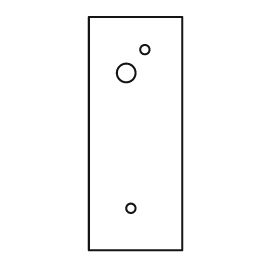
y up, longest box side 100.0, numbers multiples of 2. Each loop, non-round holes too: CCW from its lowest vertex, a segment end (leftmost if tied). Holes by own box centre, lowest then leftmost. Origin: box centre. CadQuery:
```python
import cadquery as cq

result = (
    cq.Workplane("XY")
    .moveTo(-20.0, -50.0)
    .lineTo(20.0, -50.0)
    .lineTo(20.0, 50.0)
    .lineTo(-20.0, 50.0)
    .close()
    .moveTo(-2.0, -32.0)
    .circle(2.0)
    .moveTo(-4.0, 26.0)
    .circle(4.0)
    .moveTo(4.0, 36.0)
    .circle(2.0)
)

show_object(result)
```